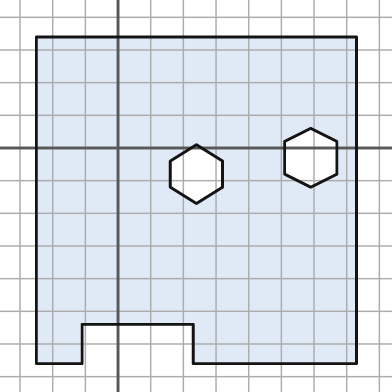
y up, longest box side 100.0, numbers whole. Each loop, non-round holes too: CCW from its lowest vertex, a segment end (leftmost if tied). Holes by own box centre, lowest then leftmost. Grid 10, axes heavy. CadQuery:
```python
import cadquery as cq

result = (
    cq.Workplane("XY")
    .moveTo(-25.0, -66.0)
    .lineTo(-11.0, -66.0)
    .lineTo(-11.0, -54.0)
    .lineTo(23.0, -54.0)
    .lineTo(23.0, -66.0)
    .lineTo(73.0, -66.0)
    .lineTo(73.0, 34.0)
    .lineTo(-25.0, 34.0)
    .close()
    .moveTo(24.0, -17.0)
    .lineTo(32.0, -12.0)
    .lineTo(32.0, -4.0)
    .lineTo(24.0, 1.0)
    .lineTo(16.0, -4.0)
    .lineTo(16.0, -12.0)
    .close()
    .moveTo(59.0, -12.0)
    .lineTo(67.0, -8.0)
    .lineTo(67.0, 2.0)
    .lineTo(59.0, 6.0)
    .lineTo(51.0, 2.0)
    .lineTo(51.0, -8.0)
    .close()
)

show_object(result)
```